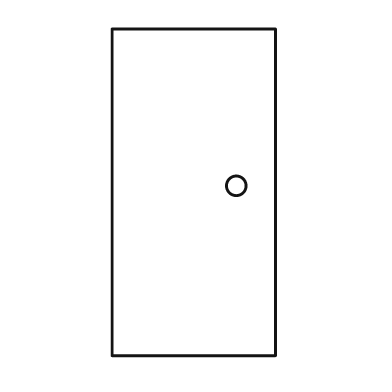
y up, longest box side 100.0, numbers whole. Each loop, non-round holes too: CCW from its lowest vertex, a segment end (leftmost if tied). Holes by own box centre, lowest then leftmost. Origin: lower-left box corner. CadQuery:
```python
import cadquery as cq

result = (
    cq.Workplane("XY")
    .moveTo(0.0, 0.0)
    .lineTo(50.0, 0.0)
    .lineTo(50.0, 100.0)
    .lineTo(0.0, 100.0)
    .close()
    .moveTo(38.0, 52.0)
    .circle(3.0)
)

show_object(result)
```